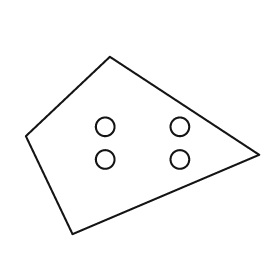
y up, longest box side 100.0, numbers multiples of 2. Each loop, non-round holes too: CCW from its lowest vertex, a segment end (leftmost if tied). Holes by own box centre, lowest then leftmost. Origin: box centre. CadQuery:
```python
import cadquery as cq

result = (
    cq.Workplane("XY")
    .moveTo(-30.0, -38.0)
    .lineTo(50.0, -4.0)
    .lineTo(-14.0, 38.0)
    .lineTo(-50.0, 4.0)
    .close()
    .moveTo(-16.0, -6.0)
    .circle(4.0)
    .moveTo(16.0, -6.0)
    .circle(4.0)
    .moveTo(-16.0, 8.0)
    .circle(4.0)
    .moveTo(16.0, 8.0)
    .circle(4.0)
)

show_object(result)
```